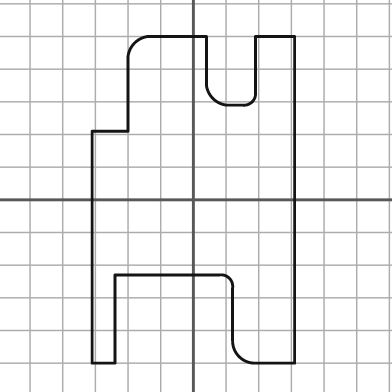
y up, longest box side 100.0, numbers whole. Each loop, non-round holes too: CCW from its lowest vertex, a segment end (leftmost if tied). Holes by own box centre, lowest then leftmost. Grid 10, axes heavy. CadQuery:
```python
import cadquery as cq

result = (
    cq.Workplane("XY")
    .moveTo(-31.0, -50.0)
    .lineTo(-24.0, -50.0)
    .lineTo(-24.0, -23.0)
    .lineTo(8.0, -23.0)
    .threePointArc((11.0, -24.0), (12.0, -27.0))
    .lineTo(12.0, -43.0)
    .threePointArc((14.0, -48.0), (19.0, -50.0))
    .lineTo(31.0, -50.0)
    .lineTo(31.0, 50.0)
    .lineTo(19.0, 50.0)
    .lineTo(19.0, 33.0)
    .threePointArc((18.0, 30.0), (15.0, 29.0))
    .lineTo(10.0, 29.0)
    .threePointArc((6.0, 31.0), (4.0, 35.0))
    .lineTo(4.0, 50.0)
    .lineTo(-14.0, 50.0)
    .threePointArc((-18.0, 48.0), (-20.0, 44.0))
    .lineTo(-20.0, 21.0)
    .lineTo(-31.0, 21.0)
    .close()
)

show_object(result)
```